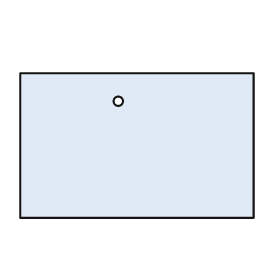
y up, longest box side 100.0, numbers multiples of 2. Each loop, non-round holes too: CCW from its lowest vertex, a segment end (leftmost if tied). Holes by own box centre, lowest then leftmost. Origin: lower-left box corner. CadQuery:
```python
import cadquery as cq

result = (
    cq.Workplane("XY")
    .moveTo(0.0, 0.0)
    .lineTo(100.0, 0.0)
    .lineTo(100.0, 62.0)
    .lineTo(0.0, 62.0)
    .close()
    .moveTo(42.0, 50.0)
    .circle(2.0)
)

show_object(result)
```